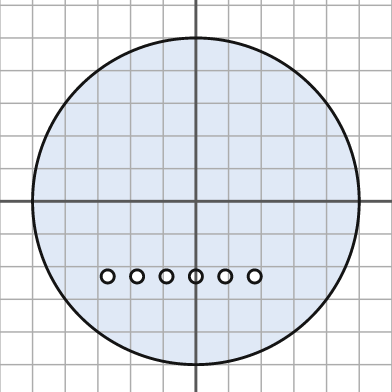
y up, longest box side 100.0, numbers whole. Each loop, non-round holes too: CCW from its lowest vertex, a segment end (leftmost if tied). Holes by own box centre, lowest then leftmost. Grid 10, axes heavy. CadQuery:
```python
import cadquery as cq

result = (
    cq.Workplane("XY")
    .moveTo(0.0, 0.0)
    .circle(50.0)
    .moveTo(-27.0, -23.0)
    .circle(2.0)
    .moveTo(-18.0, -23.0)
    .circle(2.0)
    .moveTo(-9.0, -23.0)
    .circle(2.0)
    .moveTo(0.0, -23.0)
    .circle(2.0)
    .moveTo(9.0, -23.0)
    .circle(2.0)
    .moveTo(18.0, -23.0)
    .circle(2.0)
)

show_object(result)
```